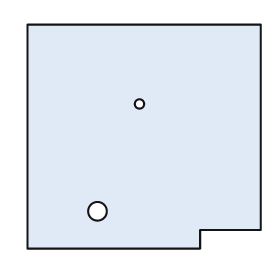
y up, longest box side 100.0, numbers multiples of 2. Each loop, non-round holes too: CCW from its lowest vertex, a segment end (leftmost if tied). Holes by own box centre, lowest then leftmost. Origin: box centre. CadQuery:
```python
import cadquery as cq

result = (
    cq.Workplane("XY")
    .moveTo(-50.0, -48.0)
    .lineTo(24.0, -48.0)
    .lineTo(24.0, -40.0)
    .lineTo(50.0, -40.0)
    .lineTo(50.0, 48.0)
    .lineTo(-50.0, 48.0)
    .close()
    .moveTo(-20.0, -32.0)
    .circle(4.0)
    .moveTo(-2.0, 14.0)
    .circle(2.0)
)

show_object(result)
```